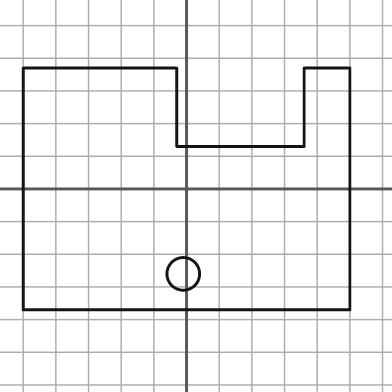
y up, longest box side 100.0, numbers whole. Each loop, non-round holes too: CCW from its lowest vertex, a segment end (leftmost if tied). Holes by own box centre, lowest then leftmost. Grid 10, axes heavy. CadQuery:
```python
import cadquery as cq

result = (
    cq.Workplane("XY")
    .moveTo(-50.0, -37.0)
    .lineTo(50.0, -37.0)
    .lineTo(50.0, 37.0)
    .lineTo(36.0, 37.0)
    .lineTo(36.0, 13.0)
    .lineTo(-3.0, 13.0)
    .lineTo(-3.0, 37.0)
    .lineTo(-50.0, 37.0)
    .close()
    .moveTo(-1.0, -26.0)
    .circle(5.0)
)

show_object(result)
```